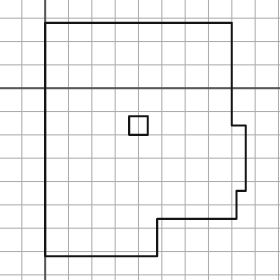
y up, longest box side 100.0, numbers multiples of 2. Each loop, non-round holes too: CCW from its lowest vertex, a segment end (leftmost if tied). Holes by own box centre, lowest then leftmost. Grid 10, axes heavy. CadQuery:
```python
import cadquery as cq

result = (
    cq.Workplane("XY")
    .moveTo(0.0, -72.0)
    .lineTo(48.0, -72.0)
    .lineTo(48.0, -56.0)
    .lineTo(82.0, -56.0)
    .lineTo(82.0, -44.0)
    .lineTo(86.0, -44.0)
    .lineTo(86.0, -16.0)
    .lineTo(80.0, -16.0)
    .lineTo(80.0, 28.0)
    .lineTo(0.0, 28.0)
    .close()
    .moveTo(36.0, -20.0)
    .lineTo(44.0, -20.0)
    .lineTo(44.0, -12.0)
    .lineTo(36.0, -12.0)
    .close()
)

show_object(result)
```